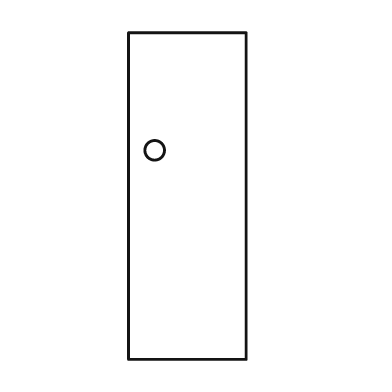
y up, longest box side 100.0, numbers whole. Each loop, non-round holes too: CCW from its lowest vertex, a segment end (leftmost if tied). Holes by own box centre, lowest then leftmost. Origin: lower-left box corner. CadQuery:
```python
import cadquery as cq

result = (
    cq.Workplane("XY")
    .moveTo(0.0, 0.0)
    .lineTo(36.0, 0.0)
    .lineTo(36.0, 100.0)
    .lineTo(0.0, 100.0)
    .close()
    .moveTo(8.0, 64.0)
    .circle(3.0)
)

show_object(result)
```